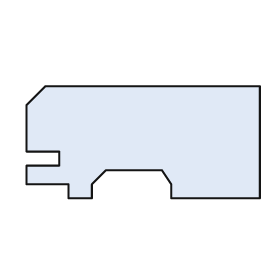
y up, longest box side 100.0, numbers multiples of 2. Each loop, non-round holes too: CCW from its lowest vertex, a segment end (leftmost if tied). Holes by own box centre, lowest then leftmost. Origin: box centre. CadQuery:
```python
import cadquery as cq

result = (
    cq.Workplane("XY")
    .moveTo(-32.0, -24.0)
    .lineTo(-22.0, -24.0)
    .lineTo(-22.0, -18.0)
    .lineTo(-16.0, -12.0)
    .lineTo(8.0, -12.0)
    .lineTo(12.0, -18.0)
    .lineTo(12.0, -24.0)
    .lineTo(50.0, -24.0)
    .lineTo(50.0, 24.0)
    .lineTo(-42.0, 24.0)
    .lineTo(-50.0, 16.0)
    .lineTo(-50.0, -4.0)
    .lineTo(-36.0, -4.0)
    .lineTo(-36.0, -10.0)
    .lineTo(-50.0, -10.0)
    .lineTo(-50.0, -18.0)
    .lineTo(-32.0, -18.0)
    .close()
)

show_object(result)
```